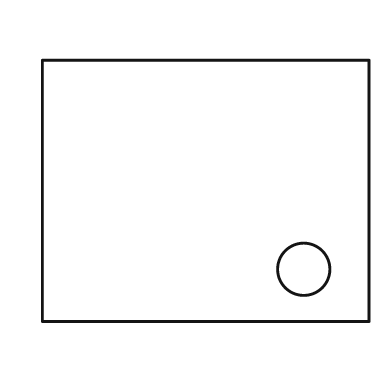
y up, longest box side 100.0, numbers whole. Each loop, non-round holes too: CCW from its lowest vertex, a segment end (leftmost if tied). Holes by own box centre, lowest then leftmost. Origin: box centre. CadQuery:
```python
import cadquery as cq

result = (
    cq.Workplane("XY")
    .moveTo(-50.0, -40.0)
    .lineTo(50.0, -40.0)
    .lineTo(50.0, 40.0)
    .lineTo(-50.0, 40.0)
    .close()
    .moveTo(30.0, -24.0)
    .circle(8.0)
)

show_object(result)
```